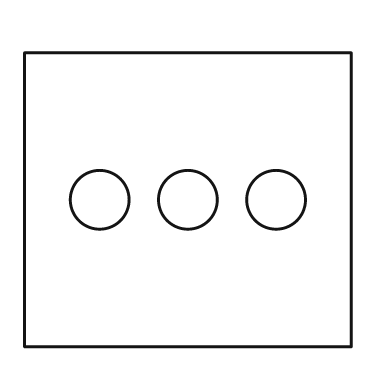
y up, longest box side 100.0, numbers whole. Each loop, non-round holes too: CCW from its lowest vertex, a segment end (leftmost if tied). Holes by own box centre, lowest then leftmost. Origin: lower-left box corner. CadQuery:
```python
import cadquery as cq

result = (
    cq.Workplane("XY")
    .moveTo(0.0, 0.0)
    .lineTo(100.0, 0.0)
    .lineTo(100.0, 90.0)
    .lineTo(0.0, 90.0)
    .close()
    .moveTo(23.0, 45.0)
    .circle(9.0)
    .moveTo(50.0, 45.0)
    .circle(9.0)
    .moveTo(77.0, 45.0)
    .circle(9.0)
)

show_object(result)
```